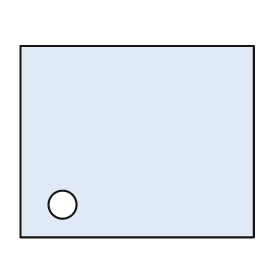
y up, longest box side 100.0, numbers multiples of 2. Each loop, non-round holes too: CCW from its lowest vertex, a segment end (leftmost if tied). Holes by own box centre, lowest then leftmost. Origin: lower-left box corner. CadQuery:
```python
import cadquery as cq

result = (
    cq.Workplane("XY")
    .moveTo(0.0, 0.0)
    .lineTo(100.0, 0.0)
    .lineTo(100.0, 82.0)
    .lineTo(0.0, 82.0)
    .close()
    .moveTo(18.0, 14.0)
    .circle(6.0)
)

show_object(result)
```